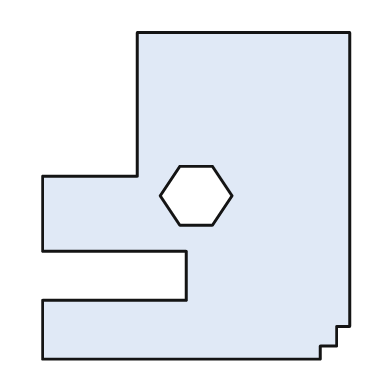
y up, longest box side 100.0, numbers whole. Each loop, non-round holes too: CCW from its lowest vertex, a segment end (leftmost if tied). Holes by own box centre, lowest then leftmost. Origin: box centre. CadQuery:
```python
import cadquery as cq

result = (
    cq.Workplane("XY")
    .moveTo(-47.0, -50.0)
    .lineTo(38.0, -50.0)
    .lineTo(38.0, -46.0)
    .lineTo(43.0, -46.0)
    .lineTo(43.0, -40.0)
    .lineTo(47.0, -40.0)
    .lineTo(47.0, 50.0)
    .lineTo(-18.0, 50.0)
    .lineTo(-18.0, 6.0)
    .lineTo(-47.0, 6.0)
    .lineTo(-47.0, -17.0)
    .lineTo(-3.0, -17.0)
    .lineTo(-3.0, -32.0)
    .lineTo(-47.0, -32.0)
    .close()
    .moveTo(-5.0, -9.0)
    .lineTo(5.0, -9.0)
    .lineTo(11.0, 0.0)
    .lineTo(5.0, 9.0)
    .lineTo(-5.0, 9.0)
    .lineTo(-11.0, 0.0)
    .close()
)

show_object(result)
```